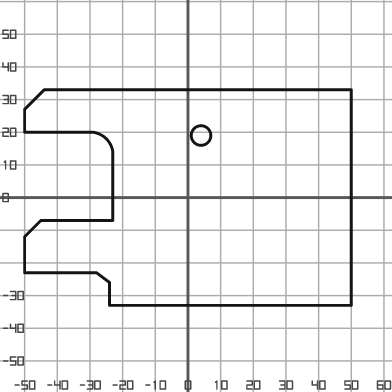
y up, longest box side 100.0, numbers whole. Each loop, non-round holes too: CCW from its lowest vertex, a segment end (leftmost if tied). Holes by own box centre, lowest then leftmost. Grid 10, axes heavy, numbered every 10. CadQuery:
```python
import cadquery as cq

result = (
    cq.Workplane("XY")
    .moveTo(-24.0, -33.0)
    .lineTo(50.0, -33.0)
    .lineTo(50.0, 33.0)
    .lineTo(-44.0, 33.0)
    .lineTo(-50.0, 27.0)
    .lineTo(-50.0, 20.0)
    .lineTo(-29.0, 20.0)
    .threePointArc((-25.0, 18.0), (-23.0, 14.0))
    .lineTo(-23.0, -7.0)
    .lineTo(-45.0, -7.0)
    .lineTo(-50.0, -12.0)
    .lineTo(-50.0, -23.0)
    .lineTo(-28.0, -23.0)
    .lineTo(-24.0, -26.0)
    .close()
    .moveTo(4.0, 19.0)
    .circle(3.0)
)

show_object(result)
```